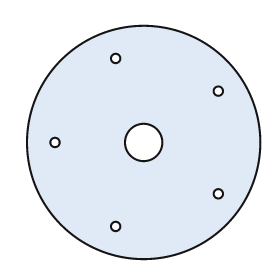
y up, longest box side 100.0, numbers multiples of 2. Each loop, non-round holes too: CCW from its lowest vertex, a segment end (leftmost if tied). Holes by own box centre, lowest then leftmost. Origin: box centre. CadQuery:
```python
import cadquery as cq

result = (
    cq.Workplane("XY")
    .moveTo(0.0, 0.0)
    .circle(50.0)
    .moveTo(-12.0, -36.0)
    .circle(2.0)
    .moveTo(32.0, -22.0)
    .circle(2.0)
    .moveTo(-38.0, 0.0)
    .circle(2.0)
    .moveTo(0.0, 0.0)
    .circle(8.0)
    .moveTo(32.0, 22.0)
    .circle(2.0)
    .moveTo(-12.0, 36.0)
    .circle(2.0)
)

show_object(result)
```